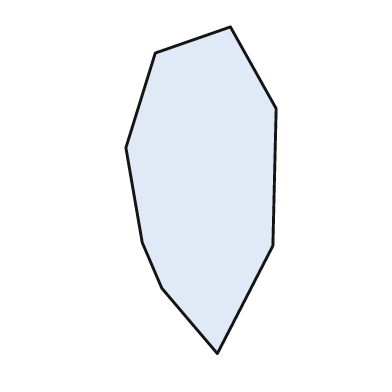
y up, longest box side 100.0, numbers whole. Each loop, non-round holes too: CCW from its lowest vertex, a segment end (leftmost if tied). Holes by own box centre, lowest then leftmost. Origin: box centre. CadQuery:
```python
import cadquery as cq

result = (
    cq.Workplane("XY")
    .moveTo(5.0, -50.0)
    .lineTo(22.0, -17.0)
    .lineTo(23.0, 25.0)
    .lineTo(9.0, 50.0)
    .lineTo(-14.0, 42.0)
    .lineTo(-23.0, 13.0)
    .lineTo(-18.0, -16.0)
    .lineTo(-12.0, -30.0)
    .close()
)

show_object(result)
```